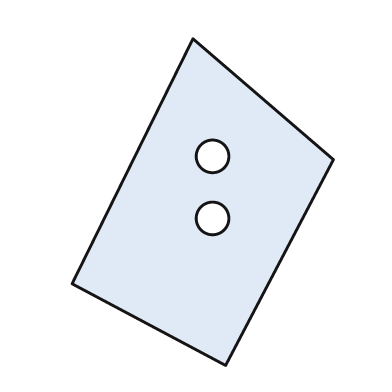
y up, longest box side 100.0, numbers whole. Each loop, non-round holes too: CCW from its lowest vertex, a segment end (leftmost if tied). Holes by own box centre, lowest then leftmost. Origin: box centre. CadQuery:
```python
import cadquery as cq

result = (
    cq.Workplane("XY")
    .moveTo(7.0, -50.0)
    .lineTo(40.0, 13.0)
    .lineTo(-3.0, 50.0)
    .lineTo(-40.0, -25.0)
    .close()
    .moveTo(3.0, -5.0)
    .circle(5.0)
    .moveTo(3.0, 14.0)
    .circle(5.0)
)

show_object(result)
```